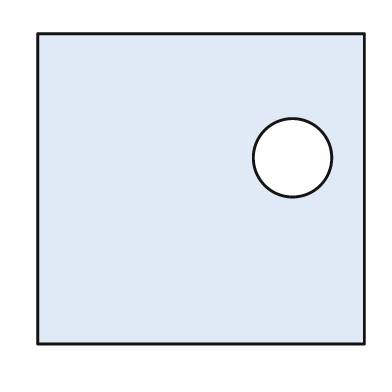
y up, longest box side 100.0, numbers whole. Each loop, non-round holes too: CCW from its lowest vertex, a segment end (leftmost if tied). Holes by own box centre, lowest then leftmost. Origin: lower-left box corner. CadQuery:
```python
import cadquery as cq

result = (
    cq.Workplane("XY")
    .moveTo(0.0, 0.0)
    .lineTo(100.0, 0.0)
    .lineTo(100.0, 95.0)
    .lineTo(0.0, 95.0)
    .close()
    .moveTo(78.0, 57.0)
    .circle(12.0)
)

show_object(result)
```